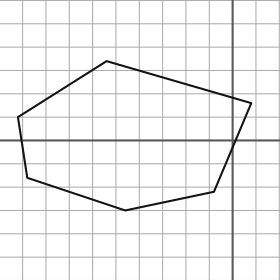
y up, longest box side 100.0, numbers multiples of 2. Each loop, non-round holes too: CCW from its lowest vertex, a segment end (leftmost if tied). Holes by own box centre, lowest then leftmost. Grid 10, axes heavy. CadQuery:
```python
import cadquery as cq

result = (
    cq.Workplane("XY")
    .moveTo(-46.0, -30.0)
    .lineTo(-8.0, -22.0)
    .lineTo(8.0, 16.0)
    .lineTo(-54.0, 34.0)
    .lineTo(-92.0, 10.0)
    .lineTo(-88.0, -16.0)
    .close()
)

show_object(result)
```